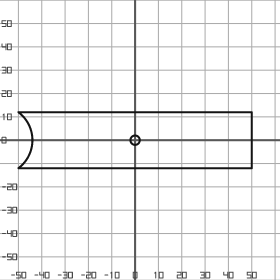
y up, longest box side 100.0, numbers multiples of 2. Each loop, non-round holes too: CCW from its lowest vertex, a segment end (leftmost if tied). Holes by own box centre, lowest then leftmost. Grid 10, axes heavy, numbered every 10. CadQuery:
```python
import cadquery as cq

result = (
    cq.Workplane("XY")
    .moveTo(-50.0, -12.0)
    .lineTo(50.0, -12.0)
    .lineTo(50.0, 12.0)
    .lineTo(-50.0, 12.0)
    .threePointArc((-44.0, 0.0), (-50.0, -12.0))
    .close()
    .moveTo(0.0, 0.0)
    .circle(2.0)
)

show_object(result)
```